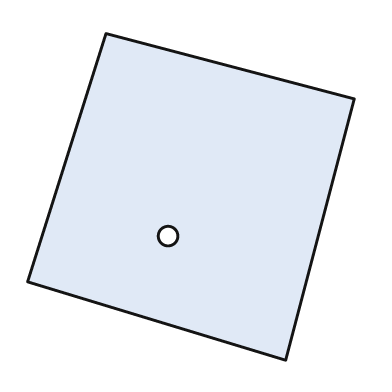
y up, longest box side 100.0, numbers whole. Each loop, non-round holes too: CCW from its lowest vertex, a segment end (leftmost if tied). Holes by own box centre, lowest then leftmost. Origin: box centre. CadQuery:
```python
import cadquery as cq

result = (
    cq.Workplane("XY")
    .moveTo(29.0, -50.0)
    .lineTo(50.0, 30.0)
    .lineTo(-26.0, 50.0)
    .lineTo(-50.0, -26.0)
    .close()
    .moveTo(-7.0, -12.0)
    .circle(3.0)
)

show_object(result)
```